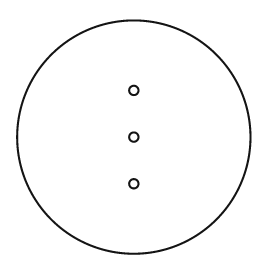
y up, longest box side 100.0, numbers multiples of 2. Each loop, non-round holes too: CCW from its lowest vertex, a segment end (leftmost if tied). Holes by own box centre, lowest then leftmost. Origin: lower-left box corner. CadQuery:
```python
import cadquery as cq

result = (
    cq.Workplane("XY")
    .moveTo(50.0, 50.0)
    .circle(50.0)
    .moveTo(50.0, 30.0)
    .circle(2.0)
    .moveTo(50.0, 50.0)
    .circle(2.0)
    .moveTo(50.0, 70.0)
    .circle(2.0)
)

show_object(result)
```